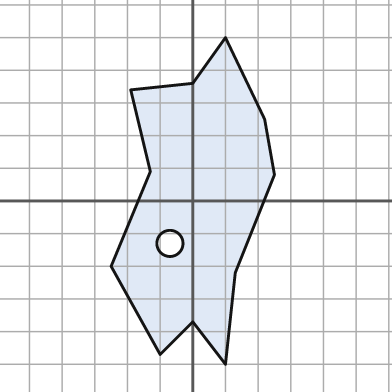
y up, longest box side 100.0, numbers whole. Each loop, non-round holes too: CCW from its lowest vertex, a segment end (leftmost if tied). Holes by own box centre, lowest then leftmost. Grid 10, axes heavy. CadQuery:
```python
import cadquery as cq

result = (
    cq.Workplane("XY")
    .moveTo(10.0, -50.0)
    .lineTo(13.0, -22.0)
    .lineTo(25.0, 8.0)
    .lineTo(22.0, 25.0)
    .lineTo(10.0, 50.0)
    .lineTo(0.0, 36.0)
    .lineTo(-19.0, 34.0)
    .lineTo(-13.0, 9.0)
    .lineTo(-25.0, -20.0)
    .lineTo(-10.0, -47.0)
    .lineTo(0.0, -37.0)
    .close()
    .moveTo(-7.0, -13.0)
    .circle(4.0)
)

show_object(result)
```